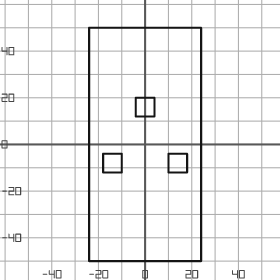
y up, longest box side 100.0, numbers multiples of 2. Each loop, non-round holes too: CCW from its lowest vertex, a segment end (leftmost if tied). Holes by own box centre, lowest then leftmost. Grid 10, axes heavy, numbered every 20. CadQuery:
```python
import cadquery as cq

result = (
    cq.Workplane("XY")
    .moveTo(-24.0, -50.0)
    .lineTo(24.0, -50.0)
    .lineTo(24.0, 50.0)
    .lineTo(-24.0, 50.0)
    .close()
    .moveTo(-18.0, -12.0)
    .lineTo(-10.0, -12.0)
    .lineTo(-10.0, -4.0)
    .lineTo(-18.0, -4.0)
    .close()
    .moveTo(10.0, -12.0)
    .lineTo(18.0, -12.0)
    .lineTo(18.0, -4.0)
    .lineTo(10.0, -4.0)
    .close()
    .moveTo(-4.0, 12.0)
    .lineTo(4.0, 12.0)
    .lineTo(4.0, 20.0)
    .lineTo(-4.0, 20.0)
    .close()
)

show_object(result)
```